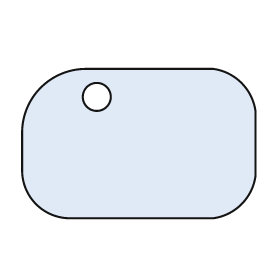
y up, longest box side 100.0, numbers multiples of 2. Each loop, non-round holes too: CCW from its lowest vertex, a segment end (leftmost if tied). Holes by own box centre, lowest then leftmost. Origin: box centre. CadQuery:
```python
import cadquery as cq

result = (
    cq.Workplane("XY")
    .moveTo(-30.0, -32.0)
    .lineTo(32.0, -32.0)
    .threePointArc((44.0, -26.0), (50.0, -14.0))
    .lineTo(50.0, 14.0)
    .threePointArc((44.0, 26.0), (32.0, 32.0))
    .lineTo(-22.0, 32.0)
    .threePointArc((-42.0, 24.0), (-50.0, 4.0))
    .lineTo(-50.0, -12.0)
    .threePointArc((-44.0, -26.0), (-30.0, -32.0))
    .close()
    .moveTo(-18.0, 20.0)
    .circle(6.0)
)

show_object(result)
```